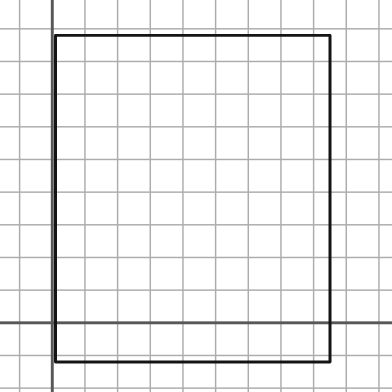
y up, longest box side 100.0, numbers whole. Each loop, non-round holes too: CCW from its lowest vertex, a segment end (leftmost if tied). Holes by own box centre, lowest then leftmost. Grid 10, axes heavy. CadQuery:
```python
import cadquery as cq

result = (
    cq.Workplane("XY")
    .moveTo(1.0, -12.0)
    .lineTo(85.0, -12.0)
    .lineTo(85.0, 88.0)
    .lineTo(1.0, 88.0)
    .close()
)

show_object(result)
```